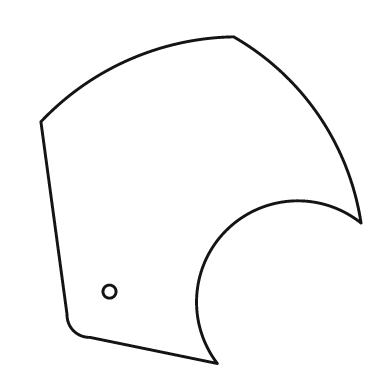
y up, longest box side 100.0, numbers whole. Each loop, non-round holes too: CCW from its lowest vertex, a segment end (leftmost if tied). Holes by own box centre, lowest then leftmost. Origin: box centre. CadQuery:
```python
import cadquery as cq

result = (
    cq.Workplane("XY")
    .moveTo(5.0, -50.0)
    .threePointArc((8.0, -9.0), (49.0, -7.0))
    .threePointArc((36.0, 26.0), (10.0, 50.0))
    .threePointArc((-22.0, 43.0), (-49.0, 24.0))
    .lineTo(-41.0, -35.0)
    .threePointArc((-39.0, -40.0), (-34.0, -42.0))
    .close()
    .moveTo(-28.0, -28.0)
    .circle(2.0)
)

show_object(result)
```